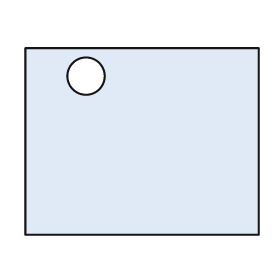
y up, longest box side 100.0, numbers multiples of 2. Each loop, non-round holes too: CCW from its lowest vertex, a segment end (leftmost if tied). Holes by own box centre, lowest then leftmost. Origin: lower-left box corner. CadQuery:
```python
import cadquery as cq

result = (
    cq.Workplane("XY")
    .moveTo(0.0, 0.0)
    .lineTo(100.0, 0.0)
    .lineTo(100.0, 80.0)
    .lineTo(0.0, 80.0)
    .close()
    .moveTo(26.0, 68.0)
    .circle(8.0)
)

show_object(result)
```